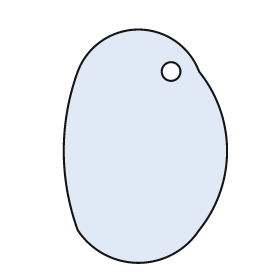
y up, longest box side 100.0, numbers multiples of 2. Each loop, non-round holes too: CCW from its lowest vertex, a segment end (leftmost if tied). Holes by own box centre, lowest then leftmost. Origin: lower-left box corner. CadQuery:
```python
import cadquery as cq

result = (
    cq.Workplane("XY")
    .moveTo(6.0, 14.0)
    .threePointArc((32.0, 0.0), (58.0, 14.0))
    .threePointArc((70.0, 48.0), (58.0, 82.0))
    .threePointArc((32.0, 100.0), (6.0, 82.0))
    .threePointArc((0.0, 48.0), (6.0, 14.0))
    .close()
    .moveTo(46.0, 82.0)
    .circle(4.0)
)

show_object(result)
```